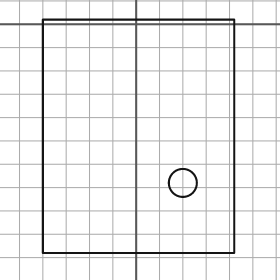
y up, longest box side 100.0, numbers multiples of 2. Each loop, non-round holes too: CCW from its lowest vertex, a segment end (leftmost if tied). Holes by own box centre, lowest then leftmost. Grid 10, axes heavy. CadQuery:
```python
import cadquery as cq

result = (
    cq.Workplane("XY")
    .moveTo(-40.0, -98.0)
    .lineTo(42.0, -98.0)
    .lineTo(42.0, 2.0)
    .lineTo(-40.0, 2.0)
    .close()
    .moveTo(20.0, -68.0)
    .circle(6.0)
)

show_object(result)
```